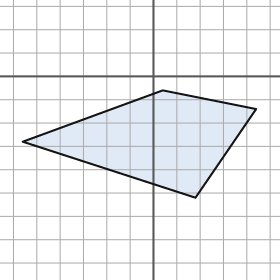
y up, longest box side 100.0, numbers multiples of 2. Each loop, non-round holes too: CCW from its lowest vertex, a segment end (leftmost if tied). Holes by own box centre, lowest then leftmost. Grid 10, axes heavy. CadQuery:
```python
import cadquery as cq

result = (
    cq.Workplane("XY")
    .moveTo(18.0, -52.0)
    .lineTo(44.0, -14.0)
    .lineTo(4.0, -6.0)
    .lineTo(-56.0, -28.0)
    .close()
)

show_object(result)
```